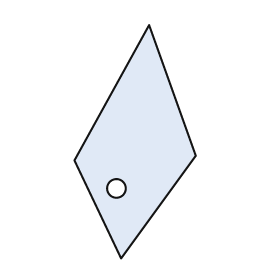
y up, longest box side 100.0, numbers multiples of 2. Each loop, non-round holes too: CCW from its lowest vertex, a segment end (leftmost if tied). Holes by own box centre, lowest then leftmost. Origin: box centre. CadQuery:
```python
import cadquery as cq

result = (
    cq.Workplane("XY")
    .moveTo(-6.0, -50.0)
    .lineTo(26.0, -6.0)
    .lineTo(6.0, 50.0)
    .lineTo(-26.0, -8.0)
    .close()
    .moveTo(-8.0, -20.0)
    .circle(4.0)
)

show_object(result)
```